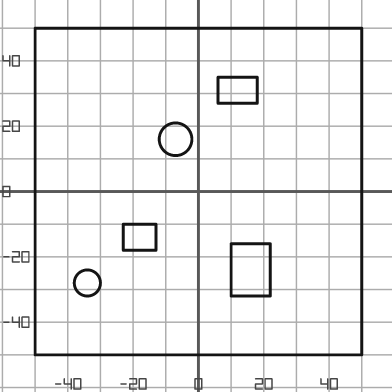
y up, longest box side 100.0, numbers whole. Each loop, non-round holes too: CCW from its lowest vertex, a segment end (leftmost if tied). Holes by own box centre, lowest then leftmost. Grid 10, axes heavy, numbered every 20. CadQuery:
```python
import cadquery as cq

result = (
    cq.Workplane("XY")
    .moveTo(-50.0, -50.0)
    .lineTo(50.0, -50.0)
    .lineTo(50.0, 50.0)
    .lineTo(-50.0, 50.0)
    .close()
    .moveTo(-34.0, -28.0)
    .circle(4.0)
    .moveTo(10.0, -32.0)
    .lineTo(22.0, -32.0)
    .lineTo(22.0, -16.0)
    .lineTo(10.0, -16.0)
    .close()
    .moveTo(-23.0, -18.0)
    .lineTo(-13.0, -18.0)
    .lineTo(-13.0, -10.0)
    .lineTo(-23.0, -10.0)
    .close()
    .moveTo(-7.0, 16.0)
    .circle(5.0)
    .moveTo(6.0, 27.0)
    .lineTo(18.0, 27.0)
    .lineTo(18.0, 35.0)
    .lineTo(6.0, 35.0)
    .close()
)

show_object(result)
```